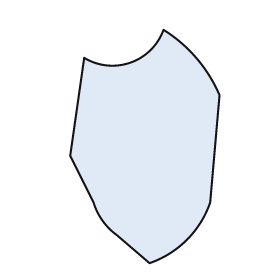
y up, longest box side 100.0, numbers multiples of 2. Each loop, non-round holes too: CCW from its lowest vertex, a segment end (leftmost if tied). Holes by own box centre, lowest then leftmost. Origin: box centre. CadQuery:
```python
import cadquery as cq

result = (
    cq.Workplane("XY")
    .moveTo(2.0, -50.0)
    .threePointArc((18.0, -40.0), (28.0, -24.0))
    .lineTo(32.0, 22.0)
    .threePointArc((22.0, 38.0), (8.0, 50.0))
    .threePointArc((-6.0, 36.0), (-26.0, 38.0))
    .lineTo(-32.0, -4.0)
    .lineTo(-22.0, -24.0)
    .threePointArc((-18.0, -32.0), (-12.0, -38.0))
    .close()
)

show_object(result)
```